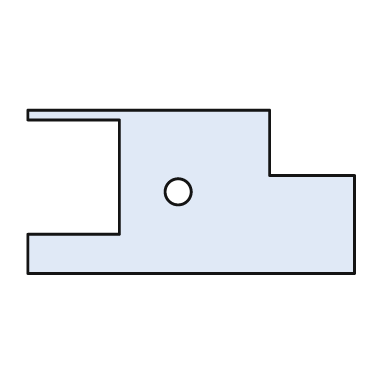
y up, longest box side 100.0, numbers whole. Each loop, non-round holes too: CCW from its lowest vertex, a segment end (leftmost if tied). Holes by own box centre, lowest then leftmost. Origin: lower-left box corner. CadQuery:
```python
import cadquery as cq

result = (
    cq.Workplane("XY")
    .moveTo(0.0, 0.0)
    .lineTo(100.0, 0.0)
    .lineTo(100.0, 30.0)
    .lineTo(74.0, 30.0)
    .lineTo(74.0, 50.0)
    .lineTo(0.0, 50.0)
    .lineTo(0.0, 47.0)
    .lineTo(28.0, 47.0)
    .lineTo(28.0, 12.0)
    .lineTo(0.0, 12.0)
    .close()
    .moveTo(46.0, 25.0)
    .circle(4.0)
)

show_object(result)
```